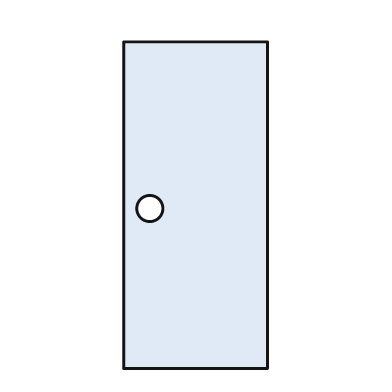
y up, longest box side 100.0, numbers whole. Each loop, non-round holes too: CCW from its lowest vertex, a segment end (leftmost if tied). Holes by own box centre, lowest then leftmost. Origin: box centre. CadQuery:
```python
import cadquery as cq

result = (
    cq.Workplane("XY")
    .moveTo(-22.0, -50.0)
    .lineTo(22.0, -50.0)
    .lineTo(22.0, 50.0)
    .lineTo(-22.0, 50.0)
    .close()
    .moveTo(-14.0, -1.0)
    .circle(4.0)
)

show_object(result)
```